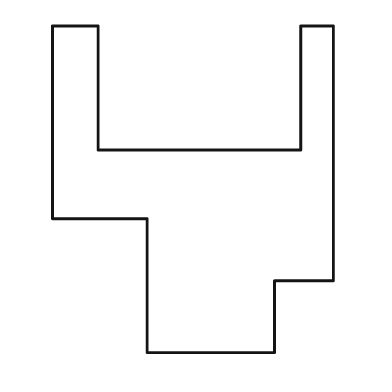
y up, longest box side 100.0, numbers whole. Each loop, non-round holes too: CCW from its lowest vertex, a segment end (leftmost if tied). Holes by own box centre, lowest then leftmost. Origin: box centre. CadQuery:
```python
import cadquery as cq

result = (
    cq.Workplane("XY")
    .moveTo(-14.0, -50.0)
    .lineTo(25.0, -50.0)
    .lineTo(25.0, -28.0)
    .lineTo(43.0, -28.0)
    .lineTo(43.0, 50.0)
    .lineTo(33.0, 50.0)
    .lineTo(33.0, 12.0)
    .lineTo(-29.0, 12.0)
    .lineTo(-29.0, 50.0)
    .lineTo(-43.0, 50.0)
    .lineTo(-43.0, -9.0)
    .lineTo(-14.0, -9.0)
    .close()
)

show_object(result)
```